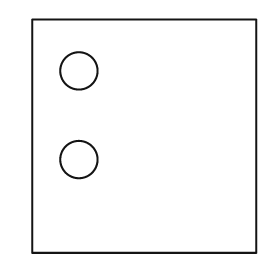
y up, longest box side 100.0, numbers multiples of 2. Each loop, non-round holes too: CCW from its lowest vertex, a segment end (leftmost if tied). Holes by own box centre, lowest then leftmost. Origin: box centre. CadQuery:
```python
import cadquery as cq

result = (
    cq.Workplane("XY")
    .moveTo(-48.0, -50.0)
    .lineTo(48.0, -50.0)
    .lineTo(48.0, 50.0)
    .lineTo(-48.0, 50.0)
    .close()
    .moveTo(-28.0, -10.0)
    .circle(8.0)
    .moveTo(-28.0, 28.0)
    .circle(8.0)
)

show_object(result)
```